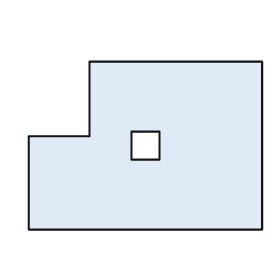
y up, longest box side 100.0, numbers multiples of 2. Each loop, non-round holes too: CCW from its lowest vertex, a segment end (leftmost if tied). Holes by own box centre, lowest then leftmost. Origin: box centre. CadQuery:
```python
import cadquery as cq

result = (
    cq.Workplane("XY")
    .moveTo(-50.0, -36.0)
    .lineTo(50.0, -36.0)
    .lineTo(50.0, 36.0)
    .lineTo(-24.0, 36.0)
    .lineTo(-24.0, 4.0)
    .lineTo(-50.0, 4.0)
    .close()
    .moveTo(-6.0, -6.0)
    .lineTo(6.0, -6.0)
    .lineTo(6.0, 6.0)
    .lineTo(-6.0, 6.0)
    .close()
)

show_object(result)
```